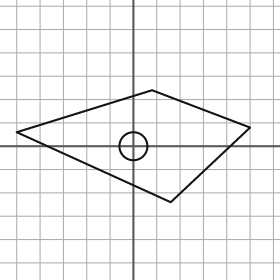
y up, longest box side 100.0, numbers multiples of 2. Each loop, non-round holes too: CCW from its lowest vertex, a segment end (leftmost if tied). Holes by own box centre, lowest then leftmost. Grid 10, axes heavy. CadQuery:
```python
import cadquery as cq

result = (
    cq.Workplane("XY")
    .moveTo(16.0, -24.0)
    .lineTo(50.0, 8.0)
    .lineTo(8.0, 24.0)
    .lineTo(-50.0, 6.0)
    .close()
    .moveTo(0.0, 0.0)
    .circle(6.0)
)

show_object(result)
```